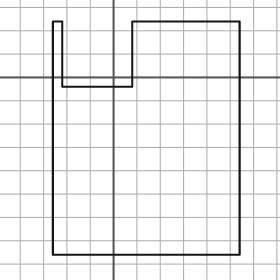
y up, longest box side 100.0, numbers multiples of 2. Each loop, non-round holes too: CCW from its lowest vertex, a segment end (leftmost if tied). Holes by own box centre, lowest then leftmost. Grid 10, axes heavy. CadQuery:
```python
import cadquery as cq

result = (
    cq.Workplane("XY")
    .moveTo(-26.0, -76.0)
    .lineTo(54.0, -76.0)
    .lineTo(54.0, 24.0)
    .lineTo(8.0, 24.0)
    .lineTo(8.0, -4.0)
    .lineTo(-22.0, -4.0)
    .lineTo(-22.0, 24.0)
    .lineTo(-26.0, 24.0)
    .close()
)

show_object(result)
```